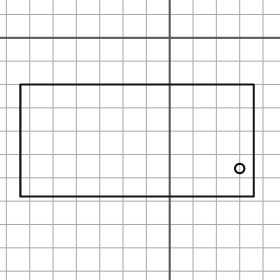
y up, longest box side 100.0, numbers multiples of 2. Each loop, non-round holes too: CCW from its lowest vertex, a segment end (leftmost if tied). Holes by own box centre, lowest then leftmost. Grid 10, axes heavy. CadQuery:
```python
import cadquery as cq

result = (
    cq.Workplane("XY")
    .moveTo(-64.0, -68.0)
    .lineTo(36.0, -68.0)
    .lineTo(36.0, -20.0)
    .lineTo(-64.0, -20.0)
    .close()
    .moveTo(30.0, -56.0)
    .circle(2.0)
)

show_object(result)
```